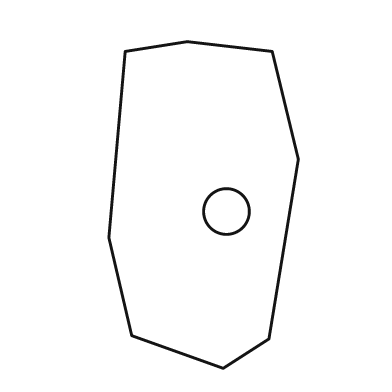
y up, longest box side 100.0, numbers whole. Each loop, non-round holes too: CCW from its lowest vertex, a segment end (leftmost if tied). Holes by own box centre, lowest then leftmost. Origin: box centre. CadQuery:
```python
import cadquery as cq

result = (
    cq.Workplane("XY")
    .moveTo(6.0, -50.0)
    .lineTo(20.0, -41.0)
    .lineTo(29.0, 14.0)
    .lineTo(21.0, 47.0)
    .lineTo(-5.0, 50.0)
    .lineTo(-24.0, 47.0)
    .lineTo(-29.0, -10.0)
    .lineTo(-22.0, -40.0)
    .close()
    .moveTo(7.0, -2.0)
    .circle(7.0)
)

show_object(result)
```